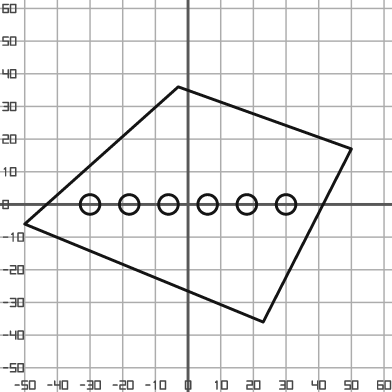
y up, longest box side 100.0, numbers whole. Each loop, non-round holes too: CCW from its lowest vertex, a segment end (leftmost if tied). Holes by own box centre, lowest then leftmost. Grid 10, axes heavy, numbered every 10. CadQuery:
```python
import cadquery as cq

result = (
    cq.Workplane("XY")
    .moveTo(23.0, -36.0)
    .lineTo(50.0, 17.0)
    .lineTo(-3.0, 36.0)
    .lineTo(-50.0, -6.0)
    .close()
    .moveTo(-30.0, 0.0)
    .circle(3.0)
    .moveTo(-18.0, 0.0)
    .circle(3.0)
    .moveTo(-6.0, 0.0)
    .circle(3.0)
    .moveTo(6.0, 0.0)
    .circle(3.0)
    .moveTo(18.0, 0.0)
    .circle(3.0)
    .moveTo(30.0, 0.0)
    .circle(3.0)
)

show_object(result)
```